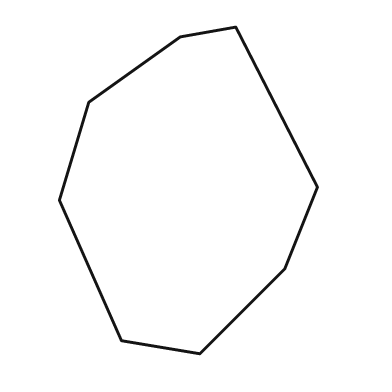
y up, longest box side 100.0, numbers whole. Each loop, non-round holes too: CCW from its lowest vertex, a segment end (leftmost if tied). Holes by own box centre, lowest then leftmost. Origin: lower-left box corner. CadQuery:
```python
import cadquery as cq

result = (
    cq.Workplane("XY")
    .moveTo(43.0, 0.0)
    .lineTo(69.0, 26.0)
    .lineTo(79.0, 51.0)
    .lineTo(54.0, 100.0)
    .lineTo(37.0, 97.0)
    .lineTo(9.0, 77.0)
    .lineTo(0.0, 47.0)
    .lineTo(19.0, 4.0)
    .close()
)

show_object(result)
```